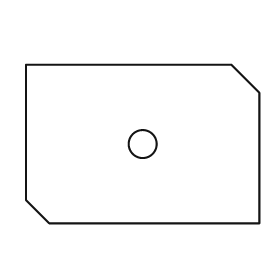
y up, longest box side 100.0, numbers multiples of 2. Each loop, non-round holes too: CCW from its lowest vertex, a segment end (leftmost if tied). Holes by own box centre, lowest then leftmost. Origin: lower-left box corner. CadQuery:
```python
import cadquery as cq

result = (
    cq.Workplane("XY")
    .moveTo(10.0, 0.0)
    .lineTo(100.0, 0.0)
    .lineTo(100.0, 56.0)
    .lineTo(88.0, 68.0)
    .lineTo(0.0, 68.0)
    .lineTo(0.0, 10.0)
    .close()
    .moveTo(50.0, 34.0)
    .circle(6.0)
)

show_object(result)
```